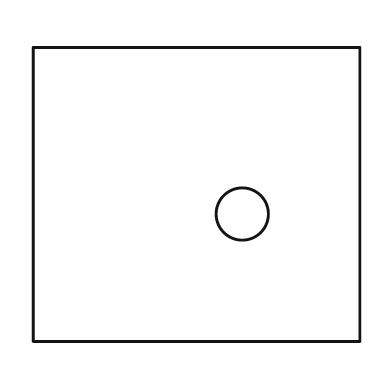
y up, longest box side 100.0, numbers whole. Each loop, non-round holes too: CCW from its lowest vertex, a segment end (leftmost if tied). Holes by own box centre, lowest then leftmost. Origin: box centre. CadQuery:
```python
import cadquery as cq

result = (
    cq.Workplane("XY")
    .moveTo(-50.0, -45.0)
    .lineTo(50.0, -45.0)
    .lineTo(50.0, 45.0)
    .lineTo(-50.0, 45.0)
    .close()
    .moveTo(14.0, -6.0)
    .circle(8.0)
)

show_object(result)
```